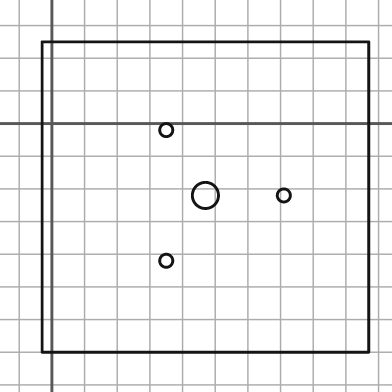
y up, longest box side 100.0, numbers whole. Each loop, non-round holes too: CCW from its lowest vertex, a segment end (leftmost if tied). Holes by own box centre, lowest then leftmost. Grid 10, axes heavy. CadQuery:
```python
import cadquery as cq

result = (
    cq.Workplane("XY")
    .moveTo(-3.0, -70.0)
    .lineTo(97.0, -70.0)
    .lineTo(97.0, 25.0)
    .lineTo(-3.0, 25.0)
    .close()
    .moveTo(35.0, -42.0)
    .circle(2.0)
    .moveTo(47.0, -22.0)
    .circle(4.0)
    .moveTo(71.0, -22.0)
    .circle(2.0)
    .moveTo(35.0, -2.0)
    .circle(2.0)
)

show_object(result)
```